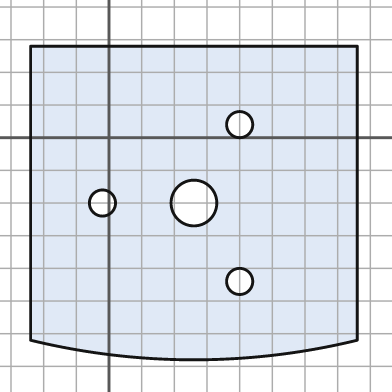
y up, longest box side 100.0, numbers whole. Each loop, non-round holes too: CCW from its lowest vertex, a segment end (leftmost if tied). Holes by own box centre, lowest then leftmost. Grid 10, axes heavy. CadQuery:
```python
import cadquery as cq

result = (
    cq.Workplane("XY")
    .moveTo(-24.0, -62.0)
    .threePointArc((26.0, -68.0), (76.0, -62.0))
    .lineTo(76.0, 28.0)
    .lineTo(-24.0, 28.0)
    .close()
    .moveTo(40.0, -44.0)
    .circle(4.0)
    .moveTo(-2.0, -20.0)
    .circle(4.0)
    .moveTo(26.0, -20.0)
    .circle(7.0)
    .moveTo(40.0, 4.0)
    .circle(4.0)
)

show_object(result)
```